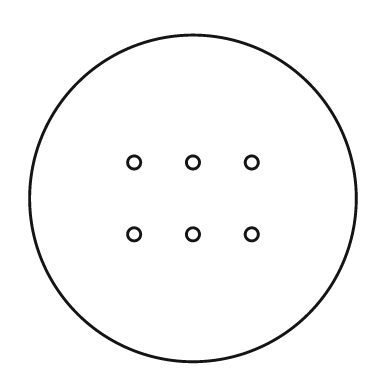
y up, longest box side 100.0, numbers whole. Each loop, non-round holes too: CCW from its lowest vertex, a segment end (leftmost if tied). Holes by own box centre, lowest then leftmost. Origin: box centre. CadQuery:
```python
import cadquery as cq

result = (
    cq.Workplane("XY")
    .moveTo(0.0, 0.0)
    .circle(50.0)
    .moveTo(-18.0, -11.0)
    .circle(2.0)
    .moveTo(0.0, -11.0)
    .circle(2.0)
    .moveTo(18.0, -11.0)
    .circle(2.0)
    .moveTo(-18.0, 11.0)
    .circle(2.0)
    .moveTo(0.0, 11.0)
    .circle(2.0)
    .moveTo(18.0, 11.0)
    .circle(2.0)
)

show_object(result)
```